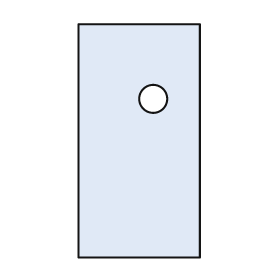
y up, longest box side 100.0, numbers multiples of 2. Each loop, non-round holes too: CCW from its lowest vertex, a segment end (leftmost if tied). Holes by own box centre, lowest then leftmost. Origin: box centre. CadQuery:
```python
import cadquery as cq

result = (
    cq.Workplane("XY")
    .moveTo(-26.0, -50.0)
    .lineTo(26.0, -50.0)
    .lineTo(26.0, 50.0)
    .lineTo(-26.0, 50.0)
    .close()
    .moveTo(6.0, 18.0)
    .circle(6.0)
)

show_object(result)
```